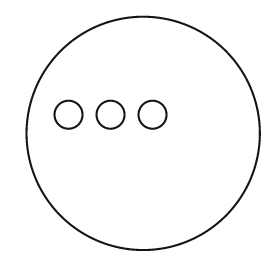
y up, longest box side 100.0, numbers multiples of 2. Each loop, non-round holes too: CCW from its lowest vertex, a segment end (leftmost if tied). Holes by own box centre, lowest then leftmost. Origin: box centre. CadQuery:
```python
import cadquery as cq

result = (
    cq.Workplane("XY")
    .moveTo(0.0, 0.0)
    .circle(50.0)
    .moveTo(-32.0, 8.0)
    .circle(6.0)
    .moveTo(-14.0, 8.0)
    .circle(6.0)
    .moveTo(4.0, 8.0)
    .circle(6.0)
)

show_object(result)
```